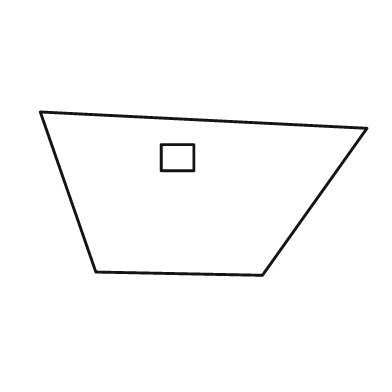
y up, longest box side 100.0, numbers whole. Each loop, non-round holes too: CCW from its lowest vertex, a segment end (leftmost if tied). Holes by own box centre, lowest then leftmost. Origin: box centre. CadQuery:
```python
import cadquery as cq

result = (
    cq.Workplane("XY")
    .moveTo(18.0, -25.0)
    .lineTo(50.0, 20.0)
    .lineTo(-50.0, 25.0)
    .lineTo(-33.0, -24.0)
    .close()
    .moveTo(-13.0, 7.0)
    .lineTo(-3.0, 7.0)
    .lineTo(-3.0, 15.0)
    .lineTo(-13.0, 15.0)
    .close()
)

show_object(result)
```